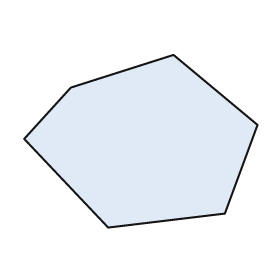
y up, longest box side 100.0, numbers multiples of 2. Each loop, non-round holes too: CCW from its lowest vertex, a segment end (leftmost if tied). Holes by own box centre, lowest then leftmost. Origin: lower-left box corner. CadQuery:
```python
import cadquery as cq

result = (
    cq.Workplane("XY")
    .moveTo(36.0, 0.0)
    .lineTo(86.0, 6.0)
    .lineTo(100.0, 44.0)
    .lineTo(64.0, 74.0)
    .lineTo(20.0, 60.0)
    .lineTo(0.0, 38.0)
    .close()
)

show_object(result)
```